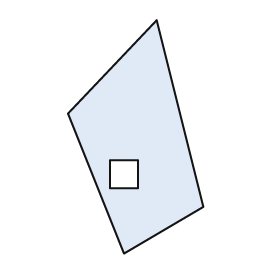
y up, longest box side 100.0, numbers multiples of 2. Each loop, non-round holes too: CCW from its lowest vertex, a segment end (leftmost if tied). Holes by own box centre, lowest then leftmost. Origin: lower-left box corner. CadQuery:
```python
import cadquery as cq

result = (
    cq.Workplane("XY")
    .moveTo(24.0, 0.0)
    .lineTo(58.0, 20.0)
    .lineTo(38.0, 100.0)
    .lineTo(0.0, 60.0)
    .close()
    .moveTo(18.0, 28.0)
    .lineTo(30.0, 28.0)
    .lineTo(30.0, 40.0)
    .lineTo(18.0, 40.0)
    .close()
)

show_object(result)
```